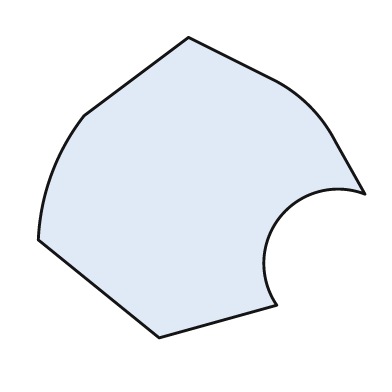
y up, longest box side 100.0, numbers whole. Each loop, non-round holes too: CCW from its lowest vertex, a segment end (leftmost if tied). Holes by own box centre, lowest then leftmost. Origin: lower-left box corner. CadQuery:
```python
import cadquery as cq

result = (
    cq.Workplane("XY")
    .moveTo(37.0, 0.0)
    .lineTo(73.0, 10.0)
    .threePointArc((74.0, 37.0), (100.0, 44.0))
    .lineTo(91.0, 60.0)
    .threePointArc((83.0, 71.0), (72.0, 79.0))
    .lineTo(46.0, 92.0)
    .lineTo(14.0, 68.0)
    .threePointArc((4.0, 50.0), (0.0, 30.0))
    .close()
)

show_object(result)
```